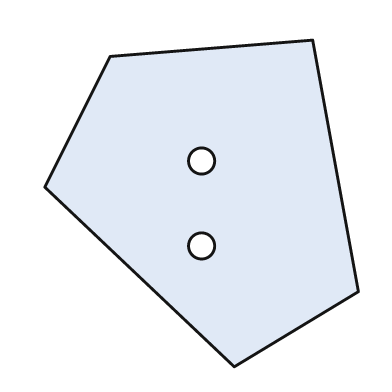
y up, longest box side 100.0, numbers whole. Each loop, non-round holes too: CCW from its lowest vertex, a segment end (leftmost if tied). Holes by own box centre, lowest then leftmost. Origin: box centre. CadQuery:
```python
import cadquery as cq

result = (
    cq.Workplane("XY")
    .moveTo(10.0, -50.0)
    .lineTo(48.0, -27.0)
    .lineTo(34.0, 50.0)
    .lineTo(-28.0, 45.0)
    .lineTo(-48.0, 5.0)
    .close()
    .moveTo(0.0, -13.0)
    .circle(4.0)
    .moveTo(0.0, 13.0)
    .circle(4.0)
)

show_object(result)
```